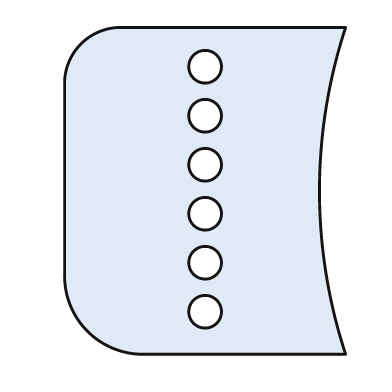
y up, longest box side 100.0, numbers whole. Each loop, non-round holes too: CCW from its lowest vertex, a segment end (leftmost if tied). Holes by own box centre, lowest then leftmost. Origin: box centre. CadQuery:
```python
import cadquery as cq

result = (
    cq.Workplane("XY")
    .moveTo(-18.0, -50.0)
    .lineTo(43.0, -50.0)
    .threePointArc((35.0, 0.0), (43.0, 50.0))
    .lineTo(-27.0, 50.0)
    .threePointArc((-38.0, 45.0), (-43.0, 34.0))
    .lineTo(-43.0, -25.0)
    .threePointArc((-36.0, -43.0), (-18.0, -50.0))
    .close()
    .moveTo(0.0, -37.0)
    .circle(5.0)
    .moveTo(0.0, -22.0)
    .circle(5.0)
    .moveTo(0.0, -7.0)
    .circle(5.0)
    .moveTo(0.0, 8.0)
    .circle(5.0)
    .moveTo(0.0, 23.0)
    .circle(5.0)
    .moveTo(0.0, 38.0)
    .circle(5.0)
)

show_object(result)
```